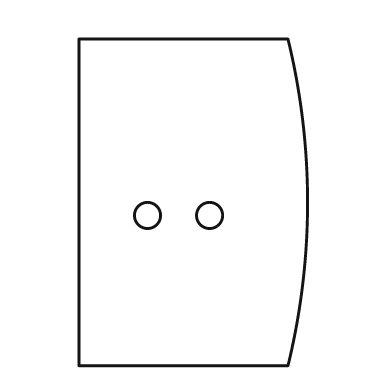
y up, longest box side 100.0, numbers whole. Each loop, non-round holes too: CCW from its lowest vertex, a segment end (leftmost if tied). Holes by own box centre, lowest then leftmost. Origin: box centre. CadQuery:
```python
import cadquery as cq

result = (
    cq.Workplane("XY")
    .moveTo(-35.0, -50.0)
    .lineTo(29.0, -50.0)
    .threePointArc((35.0, 0.0), (29.0, 50.0))
    .lineTo(-35.0, 50.0)
    .close()
    .moveTo(-14.0, -4.0)
    .circle(4.0)
    .moveTo(5.0, -4.0)
    .circle(4.0)
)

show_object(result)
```